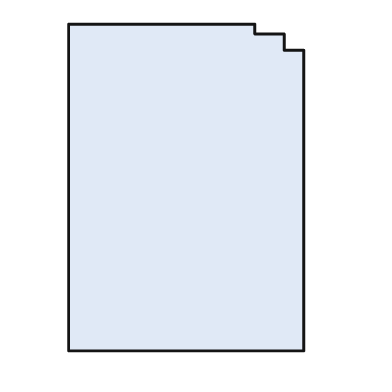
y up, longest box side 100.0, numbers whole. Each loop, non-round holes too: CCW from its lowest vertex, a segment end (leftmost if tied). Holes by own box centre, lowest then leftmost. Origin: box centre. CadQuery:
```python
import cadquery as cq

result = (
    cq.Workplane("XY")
    .moveTo(-36.0, -50.0)
    .lineTo(36.0, -50.0)
    .lineTo(36.0, 42.0)
    .lineTo(30.0, 42.0)
    .lineTo(30.0, 47.0)
    .lineTo(21.0, 47.0)
    .lineTo(21.0, 50.0)
    .lineTo(-36.0, 50.0)
    .close()
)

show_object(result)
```